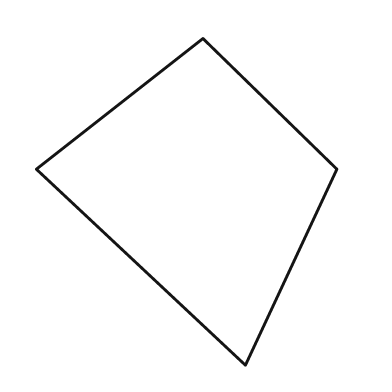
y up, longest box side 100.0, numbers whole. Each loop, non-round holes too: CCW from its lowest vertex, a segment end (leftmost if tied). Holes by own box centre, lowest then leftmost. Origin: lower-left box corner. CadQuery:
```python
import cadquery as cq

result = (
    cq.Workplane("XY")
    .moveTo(64.0, 0.0)
    .lineTo(92.0, 60.0)
    .lineTo(51.0, 100.0)
    .lineTo(0.0, 60.0)
    .close()
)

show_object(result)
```